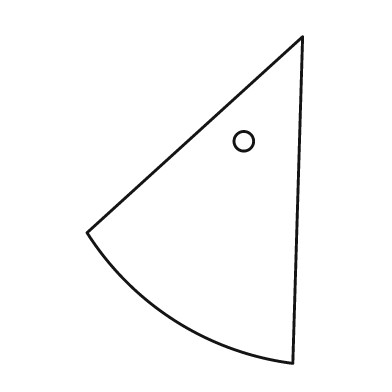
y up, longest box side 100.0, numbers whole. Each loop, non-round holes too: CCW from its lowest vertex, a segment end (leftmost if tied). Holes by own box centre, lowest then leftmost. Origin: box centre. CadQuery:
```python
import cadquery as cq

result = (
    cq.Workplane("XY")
    .moveTo(30.0, -50.0)
    .lineTo(33.0, 50.0)
    .lineTo(-33.0, -10.0)
    .threePointArc((-6.0, -37.0), (30.0, -50.0))
    .close()
    .moveTo(15.0, 18.0)
    .circle(3.0)
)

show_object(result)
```